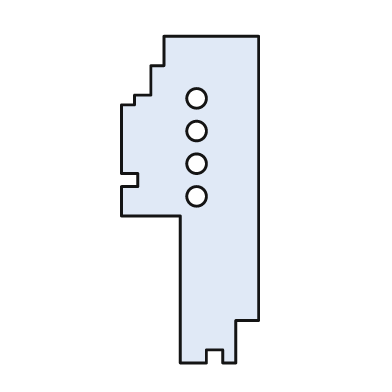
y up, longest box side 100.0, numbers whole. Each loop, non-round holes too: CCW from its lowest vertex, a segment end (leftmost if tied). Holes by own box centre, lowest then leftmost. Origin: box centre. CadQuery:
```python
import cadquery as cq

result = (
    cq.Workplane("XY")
    .moveTo(-3.0, -50.0)
    .lineTo(5.0, -50.0)
    .lineTo(5.0, -46.0)
    .lineTo(10.0, -46.0)
    .lineTo(10.0, -50.0)
    .lineTo(14.0, -50.0)
    .lineTo(14.0, -37.0)
    .lineTo(21.0, -37.0)
    .lineTo(21.0, 50.0)
    .lineTo(-8.0, 50.0)
    .lineTo(-8.0, 41.0)
    .lineTo(-12.0, 41.0)
    .lineTo(-12.0, 32.0)
    .lineTo(-17.0, 32.0)
    .lineTo(-17.0, 29.0)
    .lineTo(-21.0, 29.0)
    .lineTo(-21.0, 8.0)
    .lineTo(-16.0, 8.0)
    .lineTo(-16.0, 4.0)
    .lineTo(-21.0, 4.0)
    .lineTo(-21.0, -5.0)
    .lineTo(-3.0, -5.0)
    .close()
    .moveTo(2.0, 1.0)
    .circle(3.0)
    .moveTo(2.0, 11.0)
    .circle(3.0)
    .moveTo(2.0, 21.0)
    .circle(3.0)
    .moveTo(2.0, 31.0)
    .circle(3.0)
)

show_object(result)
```